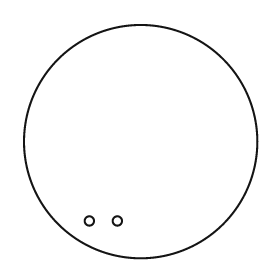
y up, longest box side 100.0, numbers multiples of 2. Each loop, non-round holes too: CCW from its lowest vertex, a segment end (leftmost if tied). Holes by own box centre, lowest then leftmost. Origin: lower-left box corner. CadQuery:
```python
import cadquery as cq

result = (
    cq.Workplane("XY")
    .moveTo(50.0, 50.0)
    .circle(50.0)
    .moveTo(28.0, 16.0)
    .circle(2.0)
    .moveTo(40.0, 16.0)
    .circle(2.0)
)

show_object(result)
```